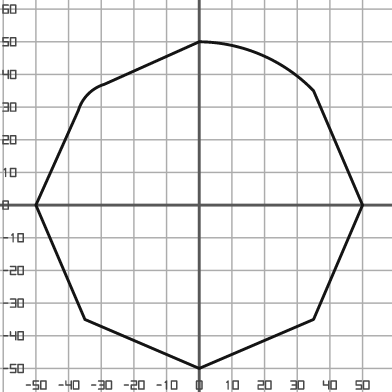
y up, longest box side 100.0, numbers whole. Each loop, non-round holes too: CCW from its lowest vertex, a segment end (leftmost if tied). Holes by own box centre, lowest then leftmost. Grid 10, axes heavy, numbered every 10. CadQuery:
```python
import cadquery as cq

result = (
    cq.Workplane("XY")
    .moveTo(0.0, -50.0)
    .lineTo(35.0, -35.0)
    .lineTo(50.0, 0.0)
    .lineTo(35.0, 35.0)
    .threePointArc((19.0, 46.0), (0.0, 50.0))
    .lineTo(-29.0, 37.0)
    .threePointArc((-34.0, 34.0), (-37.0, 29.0))
    .lineTo(-50.0, 0.0)
    .lineTo(-35.0, -35.0)
    .close()
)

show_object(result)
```